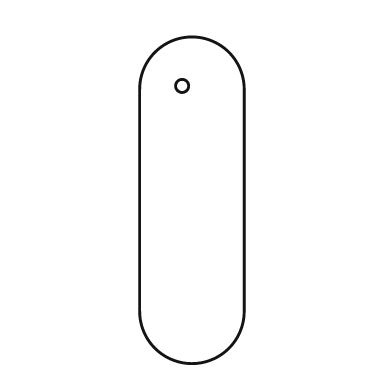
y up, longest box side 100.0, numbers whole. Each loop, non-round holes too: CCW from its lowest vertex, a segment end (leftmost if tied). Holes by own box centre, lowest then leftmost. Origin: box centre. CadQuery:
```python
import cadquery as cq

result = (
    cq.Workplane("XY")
    .moveTo(-16.0, -34.0)
    .threePointArc((0.0, -50.0), (16.0, -34.0))
    .lineTo(16.0, 34.0)
    .threePointArc((0.0, 50.0), (-16.0, 34.0))
    .close()
    .moveTo(-3.0, 35.0)
    .circle(2.0)
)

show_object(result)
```